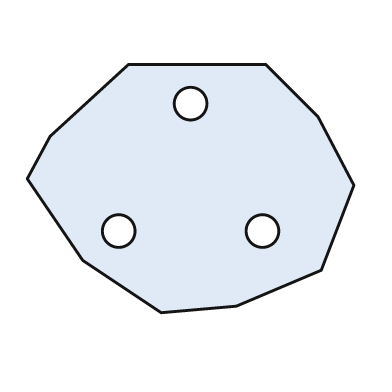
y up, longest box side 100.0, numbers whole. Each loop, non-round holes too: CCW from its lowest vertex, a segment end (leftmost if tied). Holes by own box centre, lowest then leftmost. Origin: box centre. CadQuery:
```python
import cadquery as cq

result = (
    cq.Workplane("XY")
    .moveTo(-9.0, -38.0)
    .lineTo(14.0, -36.0)
    .lineTo(40.0, -25.0)
    .lineTo(50.0, 1.0)
    .lineTo(39.0, 22.0)
    .lineTo(23.0, 38.0)
    .lineTo(-19.0, 38.0)
    .lineTo(-43.0, 16.0)
    .lineTo(-50.0, 3.0)
    .lineTo(-33.0, -22.0)
    .close()
    .moveTo(-22.0, -13.0)
    .circle(5.0)
    .moveTo(22.0, -13.0)
    .circle(5.0)
    .moveTo(0.0, 26.0)
    .circle(5.0)
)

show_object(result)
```